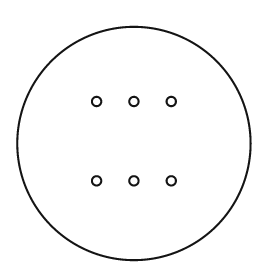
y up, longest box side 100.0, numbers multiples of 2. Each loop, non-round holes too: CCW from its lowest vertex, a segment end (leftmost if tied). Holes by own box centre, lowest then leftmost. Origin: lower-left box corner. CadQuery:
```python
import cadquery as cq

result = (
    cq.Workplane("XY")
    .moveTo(50.0, 50.0)
    .circle(50.0)
    .moveTo(34.0, 34.0)
    .circle(2.0)
    .moveTo(50.0, 34.0)
    .circle(2.0)
    .moveTo(66.0, 34.0)
    .circle(2.0)
    .moveTo(34.0, 68.0)
    .circle(2.0)
    .moveTo(50.0, 68.0)
    .circle(2.0)
    .moveTo(66.0, 68.0)
    .circle(2.0)
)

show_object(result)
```